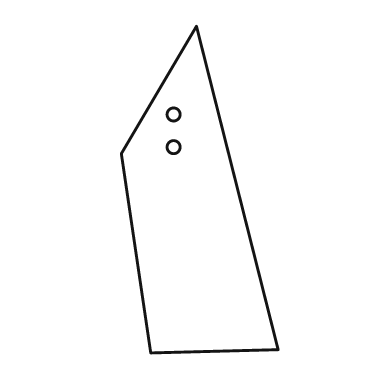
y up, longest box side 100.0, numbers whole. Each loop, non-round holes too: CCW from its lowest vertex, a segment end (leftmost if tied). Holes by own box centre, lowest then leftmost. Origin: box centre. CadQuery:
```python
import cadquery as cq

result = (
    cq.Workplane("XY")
    .moveTo(-15.0, -50.0)
    .lineTo(24.0, -49.0)
    .lineTo(-1.0, 50.0)
    .lineTo(-24.0, 11.0)
    .close()
    .moveTo(-8.0, 13.0)
    .circle(2.0)
    .moveTo(-8.0, 23.0)
    .circle(2.0)
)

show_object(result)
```